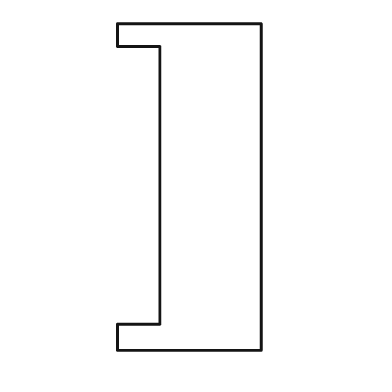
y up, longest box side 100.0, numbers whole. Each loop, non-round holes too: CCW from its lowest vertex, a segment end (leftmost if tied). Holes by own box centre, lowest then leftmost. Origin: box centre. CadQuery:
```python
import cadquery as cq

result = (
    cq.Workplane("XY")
    .moveTo(-22.0, -50.0)
    .lineTo(22.0, -50.0)
    .lineTo(22.0, 50.0)
    .lineTo(-22.0, 50.0)
    .lineTo(-22.0, 43.0)
    .lineTo(-9.0, 43.0)
    .lineTo(-9.0, -42.0)
    .lineTo(-22.0, -42.0)
    .close()
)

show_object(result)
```